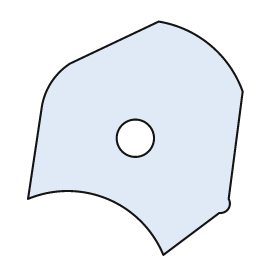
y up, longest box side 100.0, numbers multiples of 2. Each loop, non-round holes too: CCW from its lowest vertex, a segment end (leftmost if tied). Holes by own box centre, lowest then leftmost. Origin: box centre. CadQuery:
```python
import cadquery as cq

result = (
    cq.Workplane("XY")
    .moveTo(12.0, -50.0)
    .lineTo(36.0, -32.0)
    .threePointArc((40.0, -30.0), (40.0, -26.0))
    .lineTo(46.0, 20.0)
    .threePointArc((32.0, 40.0), (10.0, 50.0))
    .lineTo(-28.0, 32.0)
    .threePointArc((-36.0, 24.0), (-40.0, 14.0))
    .lineTo(-46.0, -26.0)
    .threePointArc((-12.0, -26.0), (12.0, -50.0))
    .close()
    .moveTo(0.0, 0.0)
    .circle(8.0)
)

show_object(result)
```